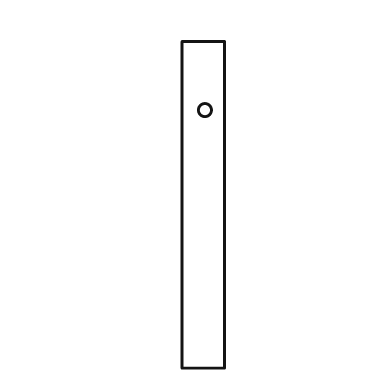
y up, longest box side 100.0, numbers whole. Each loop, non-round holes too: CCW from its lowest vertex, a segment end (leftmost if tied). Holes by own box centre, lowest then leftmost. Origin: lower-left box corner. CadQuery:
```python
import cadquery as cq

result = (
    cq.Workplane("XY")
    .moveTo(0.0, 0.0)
    .lineTo(13.0, 0.0)
    .lineTo(13.0, 100.0)
    .lineTo(0.0, 100.0)
    .close()
    .moveTo(7.0, 79.0)
    .circle(2.0)
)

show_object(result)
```